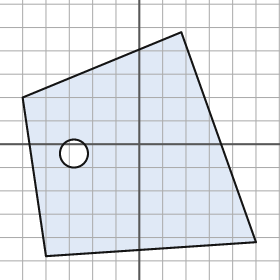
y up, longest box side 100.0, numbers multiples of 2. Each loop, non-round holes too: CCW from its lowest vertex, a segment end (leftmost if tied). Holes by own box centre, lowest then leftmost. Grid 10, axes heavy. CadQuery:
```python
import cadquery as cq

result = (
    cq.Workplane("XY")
    .moveTo(-40.0, -48.0)
    .lineTo(50.0, -42.0)
    .lineTo(18.0, 48.0)
    .lineTo(-50.0, 20.0)
    .close()
    .moveTo(-28.0, -4.0)
    .circle(6.0)
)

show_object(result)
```